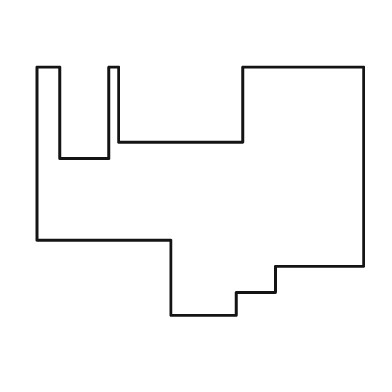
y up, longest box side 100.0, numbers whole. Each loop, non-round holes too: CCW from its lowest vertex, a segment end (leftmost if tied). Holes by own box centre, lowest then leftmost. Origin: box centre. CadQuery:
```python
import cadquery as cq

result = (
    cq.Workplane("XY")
    .moveTo(-9.0, -38.0)
    .lineTo(11.0, -38.0)
    .lineTo(11.0, -31.0)
    .lineTo(23.0, -31.0)
    .lineTo(23.0, -23.0)
    .lineTo(50.0, -23.0)
    .lineTo(50.0, 38.0)
    .lineTo(13.0, 38.0)
    .lineTo(13.0, 15.0)
    .lineTo(-25.0, 15.0)
    .lineTo(-25.0, 38.0)
    .lineTo(-28.0, 38.0)
    .lineTo(-28.0, 10.0)
    .lineTo(-43.0, 10.0)
    .lineTo(-43.0, 38.0)
    .lineTo(-50.0, 38.0)
    .lineTo(-50.0, -15.0)
    .lineTo(-9.0, -15.0)
    .close()
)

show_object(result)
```